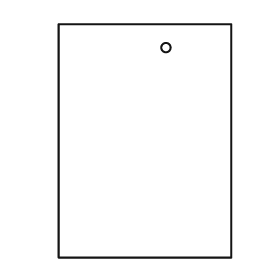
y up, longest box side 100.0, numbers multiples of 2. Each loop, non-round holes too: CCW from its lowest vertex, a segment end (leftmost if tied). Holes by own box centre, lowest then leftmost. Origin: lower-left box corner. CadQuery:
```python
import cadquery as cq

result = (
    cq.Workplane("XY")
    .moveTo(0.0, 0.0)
    .lineTo(74.0, 0.0)
    .lineTo(74.0, 100.0)
    .lineTo(0.0, 100.0)
    .close()
    .moveTo(46.0, 90.0)
    .circle(2.0)
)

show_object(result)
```